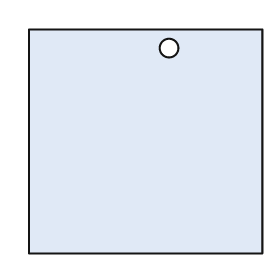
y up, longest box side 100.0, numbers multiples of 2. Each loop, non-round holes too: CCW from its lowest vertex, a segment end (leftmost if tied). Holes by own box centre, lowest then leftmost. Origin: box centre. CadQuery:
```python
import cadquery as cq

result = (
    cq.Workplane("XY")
    .moveTo(-50.0, -48.0)
    .lineTo(50.0, -48.0)
    .lineTo(50.0, 48.0)
    .lineTo(-50.0, 48.0)
    .close()
    .moveTo(10.0, 40.0)
    .circle(4.0)
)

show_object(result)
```